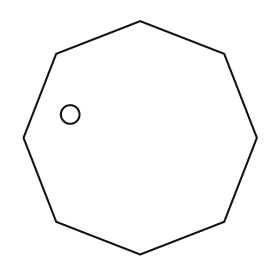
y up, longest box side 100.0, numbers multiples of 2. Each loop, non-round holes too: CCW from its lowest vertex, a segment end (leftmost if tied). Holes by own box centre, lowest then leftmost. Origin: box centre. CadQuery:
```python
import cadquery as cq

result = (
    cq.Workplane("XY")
    .moveTo(0.0, -50.0)
    .lineTo(36.0, -36.0)
    .lineTo(50.0, 0.0)
    .lineTo(36.0, 36.0)
    .lineTo(0.0, 50.0)
    .lineTo(-36.0, 36.0)
    .lineTo(-50.0, 0.0)
    .lineTo(-36.0, -36.0)
    .close()
    .moveTo(-30.0, 10.0)
    .circle(4.0)
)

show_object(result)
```